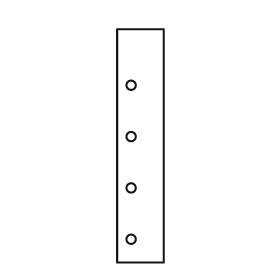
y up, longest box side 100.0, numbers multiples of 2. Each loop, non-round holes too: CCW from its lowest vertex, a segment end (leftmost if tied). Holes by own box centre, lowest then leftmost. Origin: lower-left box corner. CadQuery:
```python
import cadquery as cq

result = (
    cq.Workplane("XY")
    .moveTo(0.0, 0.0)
    .lineTo(20.0, 0.0)
    .lineTo(20.0, 100.0)
    .lineTo(0.0, 100.0)
    .close()
    .moveTo(6.0, 10.0)
    .circle(2.0)
    .moveTo(6.0, 32.0)
    .circle(2.0)
    .moveTo(6.0, 54.0)
    .circle(2.0)
    .moveTo(6.0, 76.0)
    .circle(2.0)
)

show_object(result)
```